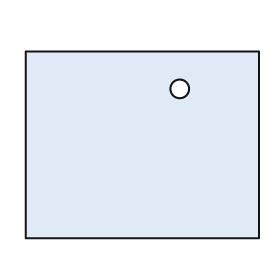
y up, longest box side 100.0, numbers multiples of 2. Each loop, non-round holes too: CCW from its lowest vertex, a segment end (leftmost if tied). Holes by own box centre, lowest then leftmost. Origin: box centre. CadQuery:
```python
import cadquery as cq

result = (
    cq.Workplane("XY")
    .moveTo(-50.0, -40.0)
    .lineTo(50.0, -40.0)
    .lineTo(50.0, 40.0)
    .lineTo(-50.0, 40.0)
    .close()
    .moveTo(16.0, 24.0)
    .circle(4.0)
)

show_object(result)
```